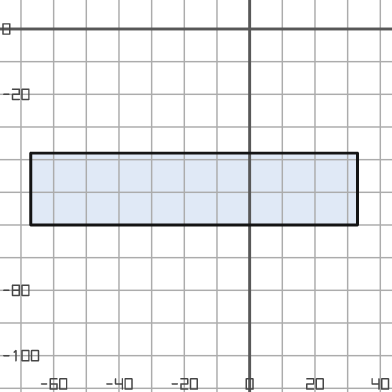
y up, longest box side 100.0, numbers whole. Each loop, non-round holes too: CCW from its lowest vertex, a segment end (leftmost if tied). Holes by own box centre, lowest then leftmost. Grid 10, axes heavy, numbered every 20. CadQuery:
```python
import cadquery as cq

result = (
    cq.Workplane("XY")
    .moveTo(-67.0, -60.0)
    .lineTo(33.0, -60.0)
    .lineTo(33.0, -38.0)
    .lineTo(-67.0, -38.0)
    .close()
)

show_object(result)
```